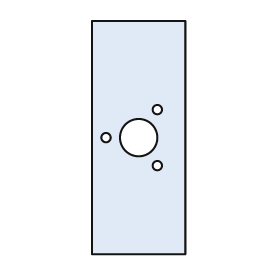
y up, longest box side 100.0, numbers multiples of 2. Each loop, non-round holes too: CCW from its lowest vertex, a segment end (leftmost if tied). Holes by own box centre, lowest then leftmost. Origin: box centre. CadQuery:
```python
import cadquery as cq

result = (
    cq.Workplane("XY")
    .moveTo(-20.0, -50.0)
    .lineTo(20.0, -50.0)
    .lineTo(20.0, 50.0)
    .lineTo(-20.0, 50.0)
    .close()
    .moveTo(8.0, -12.0)
    .circle(2.0)
    .moveTo(-14.0, 0.0)
    .circle(2.0)
    .moveTo(0.0, 0.0)
    .circle(8.0)
    .moveTo(8.0, 12.0)
    .circle(2.0)
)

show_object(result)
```